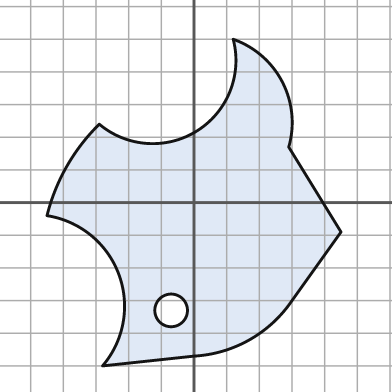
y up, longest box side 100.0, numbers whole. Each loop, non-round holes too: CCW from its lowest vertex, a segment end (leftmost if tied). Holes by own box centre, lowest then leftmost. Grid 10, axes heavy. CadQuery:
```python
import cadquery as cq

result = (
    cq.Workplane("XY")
    .moveTo(-28.0, -50.0)
    .lineTo(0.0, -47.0)
    .threePointArc((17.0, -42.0), (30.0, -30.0))
    .lineTo(45.0, -9.0)
    .lineTo(29.0, 17.0)
    .threePointArc((27.0, 37.0), (12.0, 50.0))
    .threePointArc((1.0, 22.0), (-29.0, 24.0))
    .threePointArc((-39.0, 11.0), (-45.0, -4.0))
    .threePointArc((-23.0, -22.0), (-28.0, -50.0))
    .close()
    .moveTo(-7.0, -33.0)
    .circle(5.0)
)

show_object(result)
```